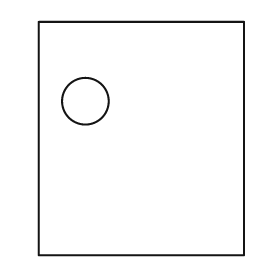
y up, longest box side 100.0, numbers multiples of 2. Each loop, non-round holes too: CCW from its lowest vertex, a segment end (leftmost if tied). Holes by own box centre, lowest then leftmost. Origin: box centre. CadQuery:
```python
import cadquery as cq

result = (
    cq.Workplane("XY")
    .moveTo(-44.0, -50.0)
    .lineTo(44.0, -50.0)
    .lineTo(44.0, 50.0)
    .lineTo(-44.0, 50.0)
    .close()
    .moveTo(-24.0, 16.0)
    .circle(10.0)
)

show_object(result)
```